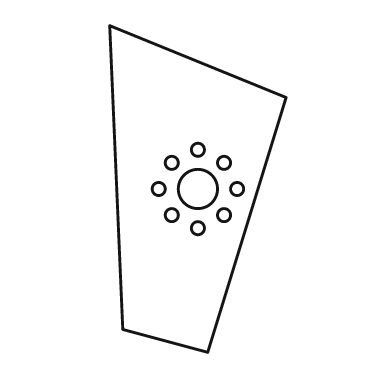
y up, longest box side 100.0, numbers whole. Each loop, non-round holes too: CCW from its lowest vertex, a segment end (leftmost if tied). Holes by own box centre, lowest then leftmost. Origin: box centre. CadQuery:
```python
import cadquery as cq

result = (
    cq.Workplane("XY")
    .moveTo(3.0, -50.0)
    .lineTo(27.0, 28.0)
    .lineTo(-27.0, 50.0)
    .lineTo(-23.0, -43.0)
    .close()
    .moveTo(0.0, -12.0)
    .circle(2.0)
    .moveTo(-8.0, -8.0)
    .circle(2.0)
    .moveTo(8.0, -8.0)
    .circle(2.0)
    .moveTo(-12.0, 0.0)
    .circle(2.0)
    .moveTo(0.0, 0.0)
    .circle(6.0)
    .moveTo(12.0, 0.0)
    .circle(2.0)
    .moveTo(-8.0, 8.0)
    .circle(2.0)
    .moveTo(8.0, 8.0)
    .circle(2.0)
    .moveTo(0.0, 12.0)
    .circle(2.0)
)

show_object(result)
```